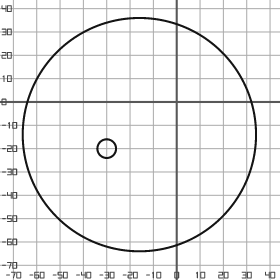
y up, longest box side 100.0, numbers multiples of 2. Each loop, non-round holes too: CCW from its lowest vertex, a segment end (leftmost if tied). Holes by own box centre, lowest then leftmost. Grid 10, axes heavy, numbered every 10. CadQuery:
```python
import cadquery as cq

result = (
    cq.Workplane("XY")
    .moveTo(-16.0, -14.0)
    .circle(50.0)
    .moveTo(-30.0, -20.0)
    .circle(4.0)
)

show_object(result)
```